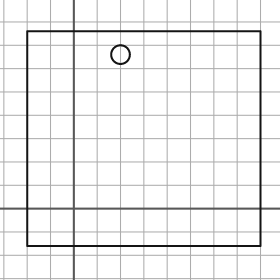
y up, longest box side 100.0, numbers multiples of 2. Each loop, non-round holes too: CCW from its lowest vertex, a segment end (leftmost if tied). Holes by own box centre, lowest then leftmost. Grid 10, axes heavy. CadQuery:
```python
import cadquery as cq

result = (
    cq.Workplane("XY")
    .moveTo(-20.0, -16.0)
    .lineTo(80.0, -16.0)
    .lineTo(80.0, 76.0)
    .lineTo(-20.0, 76.0)
    .close()
    .moveTo(20.0, 66.0)
    .circle(4.0)
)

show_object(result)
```